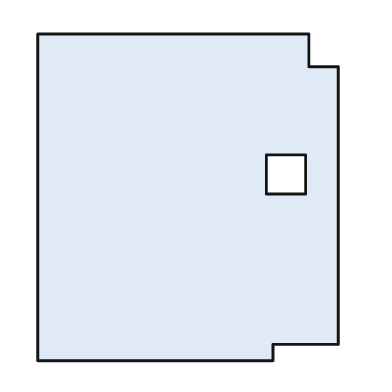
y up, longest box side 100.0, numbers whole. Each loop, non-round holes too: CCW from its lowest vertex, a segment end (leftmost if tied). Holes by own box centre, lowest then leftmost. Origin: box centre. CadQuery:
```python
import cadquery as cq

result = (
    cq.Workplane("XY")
    .moveTo(-46.0, -50.0)
    .lineTo(26.0, -50.0)
    .lineTo(26.0, -45.0)
    .lineTo(46.0, -45.0)
    .lineTo(46.0, 40.0)
    .lineTo(37.0, 40.0)
    .lineTo(37.0, 50.0)
    .lineTo(-46.0, 50.0)
    .close()
    .moveTo(24.0, 1.0)
    .lineTo(36.0, 1.0)
    .lineTo(36.0, 13.0)
    .lineTo(24.0, 13.0)
    .close()
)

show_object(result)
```